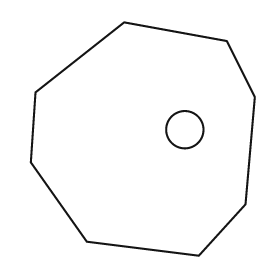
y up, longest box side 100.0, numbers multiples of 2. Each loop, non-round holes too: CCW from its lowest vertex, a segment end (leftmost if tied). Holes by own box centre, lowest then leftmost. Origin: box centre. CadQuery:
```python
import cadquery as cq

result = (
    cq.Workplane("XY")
    .moveTo(24.0, -50.0)
    .lineTo(44.0, -28.0)
    .lineTo(48.0, 18.0)
    .lineTo(36.0, 42.0)
    .lineTo(-8.0, 50.0)
    .lineTo(-46.0, 20.0)
    .lineTo(-48.0, -10.0)
    .lineTo(-24.0, -44.0)
    .close()
    .moveTo(18.0, 4.0)
    .circle(8.0)
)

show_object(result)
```